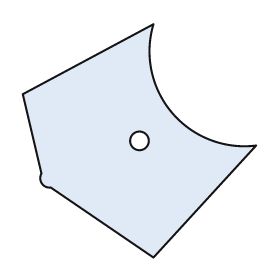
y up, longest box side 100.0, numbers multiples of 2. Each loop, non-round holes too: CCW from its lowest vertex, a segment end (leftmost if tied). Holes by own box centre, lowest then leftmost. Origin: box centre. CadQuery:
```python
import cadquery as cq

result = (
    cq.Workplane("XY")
    .moveTo(6.0, -50.0)
    .lineTo(50.0, -2.0)
    .threePointArc((14.0, 12.0), (6.0, 50.0))
    .lineTo(-50.0, 20.0)
    .lineTo(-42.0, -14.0)
    .threePointArc((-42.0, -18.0), (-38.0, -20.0))
    .close()
    .moveTo(0.0, 0.0)
    .circle(4.0)
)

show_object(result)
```